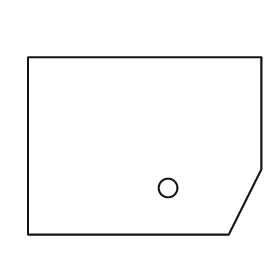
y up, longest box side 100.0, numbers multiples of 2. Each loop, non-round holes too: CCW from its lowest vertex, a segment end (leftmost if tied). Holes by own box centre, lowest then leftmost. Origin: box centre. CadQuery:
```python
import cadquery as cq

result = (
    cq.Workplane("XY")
    .moveTo(-50.0, -38.0)
    .lineTo(36.0, -38.0)
    .lineTo(50.0, -10.0)
    .lineTo(50.0, 38.0)
    .lineTo(-50.0, 38.0)
    .close()
    .moveTo(10.0, -18.0)
    .circle(4.0)
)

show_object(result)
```